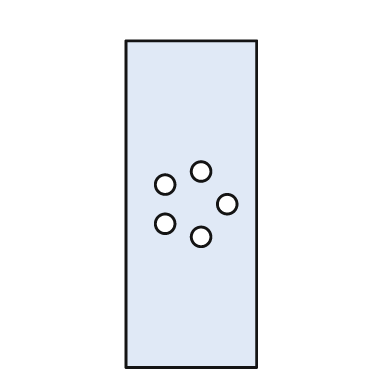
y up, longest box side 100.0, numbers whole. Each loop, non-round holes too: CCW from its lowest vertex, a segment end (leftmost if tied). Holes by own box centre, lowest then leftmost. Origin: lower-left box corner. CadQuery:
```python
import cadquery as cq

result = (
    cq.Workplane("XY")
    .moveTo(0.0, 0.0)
    .lineTo(40.0, 0.0)
    .lineTo(40.0, 100.0)
    .lineTo(0.0, 100.0)
    .close()
    .moveTo(23.0, 40.0)
    .circle(3.0)
    .moveTo(12.0, 44.0)
    .circle(3.0)
    .moveTo(31.0, 50.0)
    .circle(3.0)
    .moveTo(12.0, 56.0)
    .circle(3.0)
    .moveTo(23.0, 60.0)
    .circle(3.0)
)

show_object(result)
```